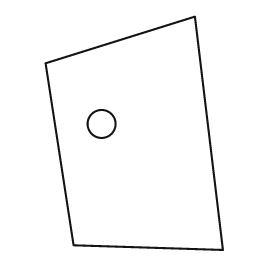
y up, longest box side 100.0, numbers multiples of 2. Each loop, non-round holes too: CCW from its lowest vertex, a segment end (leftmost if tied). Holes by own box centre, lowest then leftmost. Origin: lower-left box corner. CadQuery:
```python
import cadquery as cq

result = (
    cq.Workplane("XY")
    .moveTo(76.0, 0.0)
    .lineTo(64.0, 100.0)
    .lineTo(0.0, 80.0)
    .lineTo(12.0, 2.0)
    .close()
    .moveTo(24.0, 54.0)
    .circle(6.0)
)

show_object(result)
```